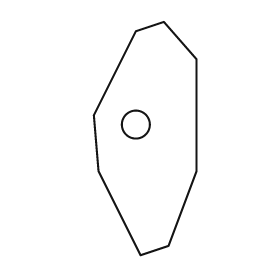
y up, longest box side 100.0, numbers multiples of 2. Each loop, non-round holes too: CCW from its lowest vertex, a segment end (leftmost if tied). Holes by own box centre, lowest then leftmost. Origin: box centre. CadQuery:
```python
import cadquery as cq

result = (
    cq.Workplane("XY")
    .moveTo(-2.0, -50.0)
    .lineTo(10.0, -46.0)
    .lineTo(22.0, -14.0)
    .lineTo(22.0, 34.0)
    .lineTo(8.0, 50.0)
    .lineTo(-4.0, 46.0)
    .lineTo(-22.0, 10.0)
    .lineTo(-20.0, -14.0)
    .close()
    .moveTo(-4.0, 6.0)
    .circle(6.0)
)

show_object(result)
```